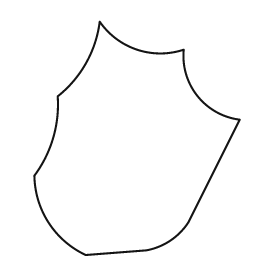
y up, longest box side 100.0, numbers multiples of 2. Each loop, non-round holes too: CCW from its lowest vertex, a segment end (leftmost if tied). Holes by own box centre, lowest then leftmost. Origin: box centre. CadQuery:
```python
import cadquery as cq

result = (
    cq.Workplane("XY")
    .moveTo(-22.0, -50.0)
    .lineTo(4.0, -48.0)
    .threePointArc((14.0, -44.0), (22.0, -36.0))
    .lineTo(44.0, 8.0)
    .threePointArc((26.0, 18.0), (20.0, 38.0))
    .threePointArc((0.0, 38.0), (-16.0, 50.0))
    .threePointArc((-22.0, 32.0), (-34.0, 18.0))
    .threePointArc((-36.0, 0.0), (-44.0, -16.0))
    .threePointArc((-38.0, -36.0), (-22.0, -50.0))
    .close()
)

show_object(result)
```